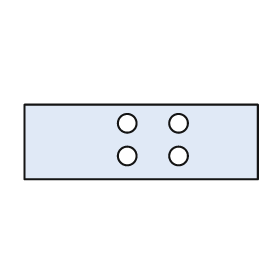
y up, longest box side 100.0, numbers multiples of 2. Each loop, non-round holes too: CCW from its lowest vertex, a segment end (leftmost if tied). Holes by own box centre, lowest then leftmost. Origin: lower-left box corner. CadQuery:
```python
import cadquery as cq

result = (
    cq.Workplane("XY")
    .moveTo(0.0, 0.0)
    .lineTo(100.0, 0.0)
    .lineTo(100.0, 32.0)
    .lineTo(0.0, 32.0)
    .close()
    .moveTo(44.0, 10.0)
    .circle(4.0)
    .moveTo(66.0, 10.0)
    .circle(4.0)
    .moveTo(44.0, 24.0)
    .circle(4.0)
    .moveTo(66.0, 24.0)
    .circle(4.0)
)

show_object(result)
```